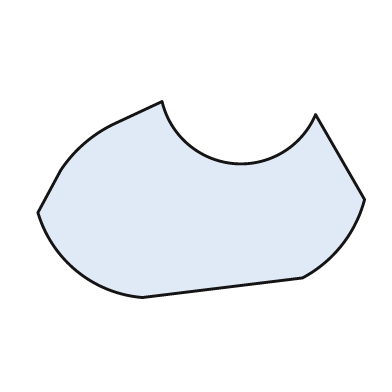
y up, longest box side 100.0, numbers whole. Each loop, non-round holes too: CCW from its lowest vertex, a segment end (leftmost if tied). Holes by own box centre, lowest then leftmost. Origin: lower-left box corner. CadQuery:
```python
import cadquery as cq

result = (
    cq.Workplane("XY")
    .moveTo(32.0, 0.0)
    .lineTo(81.0, 6.0)
    .threePointArc((93.0, 16.0), (100.0, 30.0))
    .lineTo(85.0, 56.0)
    .threePointArc((60.0, 41.0), (38.0, 60.0))
    .lineTo(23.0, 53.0)
    .threePointArc((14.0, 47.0), (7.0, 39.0))
    .lineTo(0.0, 26.0)
    .threePointArc((12.0, 8.0), (32.0, 0.0))
    .close()
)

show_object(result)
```